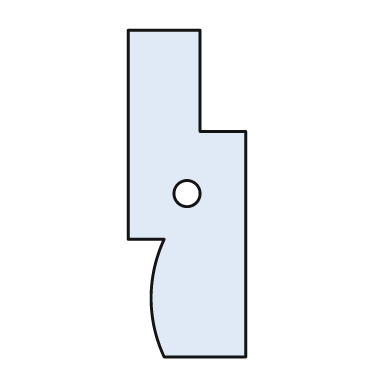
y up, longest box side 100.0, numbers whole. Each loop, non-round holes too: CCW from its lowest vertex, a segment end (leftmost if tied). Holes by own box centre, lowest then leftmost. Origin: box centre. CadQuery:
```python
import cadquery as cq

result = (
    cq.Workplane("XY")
    .moveTo(-7.0, -50.0)
    .lineTo(18.0, -50.0)
    .lineTo(18.0, 19.0)
    .lineTo(4.0, 19.0)
    .lineTo(4.0, 50.0)
    .lineTo(-18.0, 50.0)
    .lineTo(-18.0, -14.0)
    .lineTo(-7.0, -14.0)
    .threePointArc((-11.0, -32.0), (-7.0, -50.0))
    .close()
    .moveTo(0.0, 0.0)
    .circle(4.0)
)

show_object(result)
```